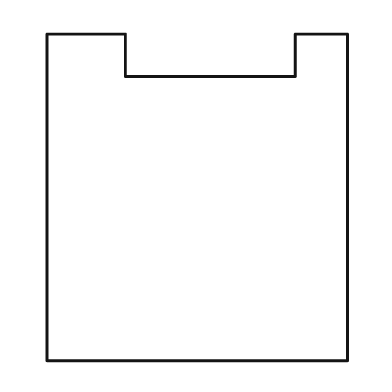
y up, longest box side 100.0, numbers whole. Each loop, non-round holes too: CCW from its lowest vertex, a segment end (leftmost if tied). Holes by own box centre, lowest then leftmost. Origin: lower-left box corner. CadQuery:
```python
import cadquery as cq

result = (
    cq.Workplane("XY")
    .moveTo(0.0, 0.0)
    .lineTo(92.0, 0.0)
    .lineTo(92.0, 100.0)
    .lineTo(76.0, 100.0)
    .lineTo(76.0, 87.0)
    .lineTo(24.0, 87.0)
    .lineTo(24.0, 100.0)
    .lineTo(0.0, 100.0)
    .close()
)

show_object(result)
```